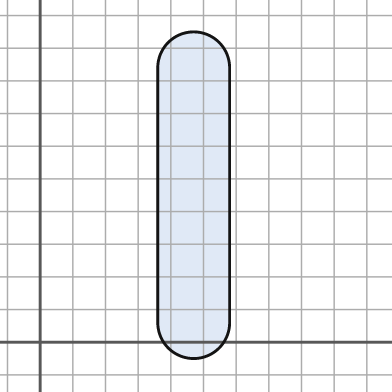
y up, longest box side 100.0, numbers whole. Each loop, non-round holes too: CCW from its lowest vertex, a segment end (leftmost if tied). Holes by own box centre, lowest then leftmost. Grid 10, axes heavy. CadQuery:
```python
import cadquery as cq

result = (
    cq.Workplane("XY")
    .moveTo(36.0, 6.0)
    .threePointArc((47.0, -5.0), (58.0, 6.0))
    .lineTo(58.0, 84.0)
    .threePointArc((47.0, 95.0), (36.0, 84.0))
    .close()
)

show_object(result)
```